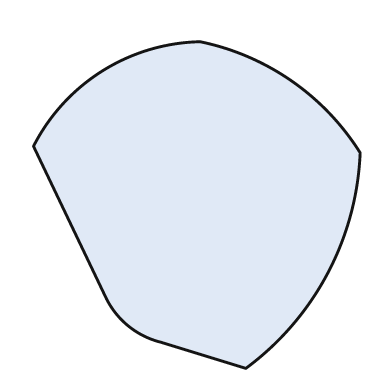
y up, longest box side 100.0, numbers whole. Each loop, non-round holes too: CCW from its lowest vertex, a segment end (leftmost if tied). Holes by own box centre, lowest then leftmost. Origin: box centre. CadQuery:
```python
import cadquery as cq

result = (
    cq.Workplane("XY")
    .moveTo(15.0, -50.0)
    .threePointArc((40.0, -21.0), (50.0, 16.0))
    .threePointArc((29.0, 38.0), (1.0, 50.0))
    .threePointArc((-29.0, 41.0), (-50.0, 18.0))
    .lineTo(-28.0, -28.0)
    .threePointArc((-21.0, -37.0), (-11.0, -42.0))
    .close()
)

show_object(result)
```